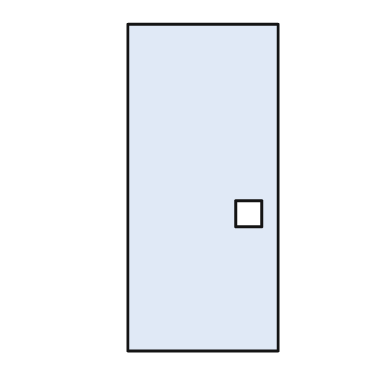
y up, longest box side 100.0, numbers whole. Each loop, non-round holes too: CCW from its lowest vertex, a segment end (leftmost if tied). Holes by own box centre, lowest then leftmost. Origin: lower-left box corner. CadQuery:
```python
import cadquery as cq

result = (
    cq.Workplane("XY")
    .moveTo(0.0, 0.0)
    .lineTo(46.0, 0.0)
    .lineTo(46.0, 100.0)
    .lineTo(0.0, 100.0)
    .close()
    .moveTo(33.0, 38.0)
    .lineTo(41.0, 38.0)
    .lineTo(41.0, 46.0)
    .lineTo(33.0, 46.0)
    .close()
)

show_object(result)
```